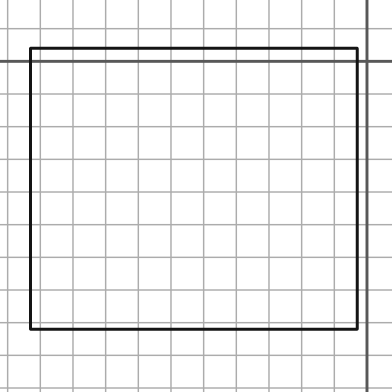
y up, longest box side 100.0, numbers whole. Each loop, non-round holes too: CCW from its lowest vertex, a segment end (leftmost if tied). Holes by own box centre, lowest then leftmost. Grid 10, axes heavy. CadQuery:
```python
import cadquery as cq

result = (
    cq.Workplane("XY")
    .moveTo(-103.0, -82.0)
    .lineTo(-3.0, -82.0)
    .lineTo(-3.0, 4.0)
    .lineTo(-103.0, 4.0)
    .close()
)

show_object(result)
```